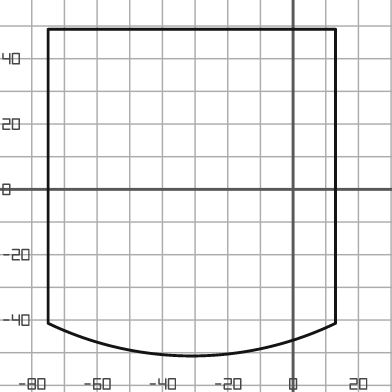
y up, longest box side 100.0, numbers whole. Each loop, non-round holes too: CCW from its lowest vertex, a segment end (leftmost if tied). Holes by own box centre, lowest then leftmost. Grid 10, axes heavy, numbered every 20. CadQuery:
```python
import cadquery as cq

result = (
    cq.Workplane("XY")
    .moveTo(-75.0, -41.0)
    .threePointArc((-31.0, -51.0), (13.0, -41.0))
    .lineTo(13.0, 49.0)
    .lineTo(-75.0, 49.0)
    .close()
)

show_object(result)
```